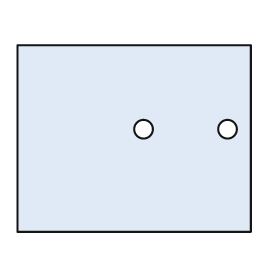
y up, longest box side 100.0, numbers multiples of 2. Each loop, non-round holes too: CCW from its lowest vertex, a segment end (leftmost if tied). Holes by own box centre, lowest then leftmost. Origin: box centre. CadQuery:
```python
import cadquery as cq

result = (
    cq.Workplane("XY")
    .moveTo(-50.0, -40.0)
    .lineTo(50.0, -40.0)
    .lineTo(50.0, 40.0)
    .lineTo(-50.0, 40.0)
    .close()
    .moveTo(4.0, 4.0)
    .circle(4.0)
    .moveTo(40.0, 4.0)
    .circle(4.0)
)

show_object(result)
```